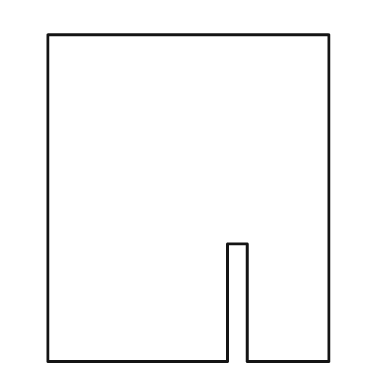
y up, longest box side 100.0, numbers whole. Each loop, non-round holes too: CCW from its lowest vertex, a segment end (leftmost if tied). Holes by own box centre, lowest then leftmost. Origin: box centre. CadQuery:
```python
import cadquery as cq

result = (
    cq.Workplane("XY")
    .moveTo(-43.0, -50.0)
    .lineTo(12.0, -50.0)
    .lineTo(12.0, -14.0)
    .lineTo(18.0, -14.0)
    .lineTo(18.0, -50.0)
    .lineTo(43.0, -50.0)
    .lineTo(43.0, 50.0)
    .lineTo(-43.0, 50.0)
    .close()
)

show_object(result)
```